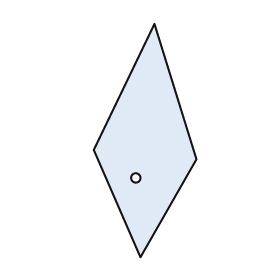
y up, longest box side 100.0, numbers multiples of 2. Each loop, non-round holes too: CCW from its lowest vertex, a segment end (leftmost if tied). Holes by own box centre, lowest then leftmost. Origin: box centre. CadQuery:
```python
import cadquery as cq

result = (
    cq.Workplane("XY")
    .moveTo(-2.0, -50.0)
    .lineTo(22.0, -8.0)
    .lineTo(4.0, 50.0)
    .lineTo(-22.0, -4.0)
    .close()
    .moveTo(-4.0, -16.0)
    .circle(2.0)
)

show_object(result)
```